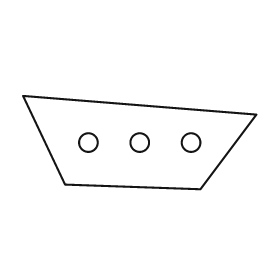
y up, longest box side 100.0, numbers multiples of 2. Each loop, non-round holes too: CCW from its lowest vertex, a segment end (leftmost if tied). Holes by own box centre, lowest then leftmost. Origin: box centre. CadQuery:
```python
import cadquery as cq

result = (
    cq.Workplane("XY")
    .moveTo(26.0, -20.0)
    .lineTo(50.0, 12.0)
    .lineTo(-50.0, 20.0)
    .lineTo(-32.0, -18.0)
    .close()
    .moveTo(-22.0, 0.0)
    .circle(4.0)
    .moveTo(0.0, 0.0)
    .circle(4.0)
    .moveTo(22.0, 0.0)
    .circle(4.0)
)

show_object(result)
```